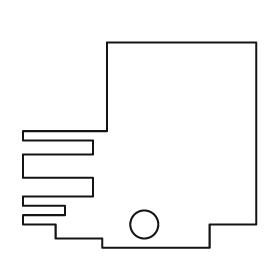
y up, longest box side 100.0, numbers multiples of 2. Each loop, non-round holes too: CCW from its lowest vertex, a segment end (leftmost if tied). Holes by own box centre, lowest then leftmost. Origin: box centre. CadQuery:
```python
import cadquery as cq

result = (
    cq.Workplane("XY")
    .moveTo(-16.0, -44.0)
    .lineTo(30.0, -44.0)
    .lineTo(30.0, -34.0)
    .lineTo(50.0, -34.0)
    .lineTo(50.0, 44.0)
    .lineTo(-14.0, 44.0)
    .lineTo(-14.0, 6.0)
    .lineTo(-50.0, 6.0)
    .lineTo(-50.0, 2.0)
    .lineTo(-20.0, 2.0)
    .lineTo(-20.0, -4.0)
    .lineTo(-50.0, -4.0)
    .lineTo(-50.0, -14.0)
    .lineTo(-20.0, -14.0)
    .lineTo(-20.0, -22.0)
    .lineTo(-50.0, -22.0)
    .lineTo(-50.0, -26.0)
    .lineTo(-32.0, -26.0)
    .lineTo(-32.0, -30.0)
    .lineTo(-50.0, -30.0)
    .lineTo(-50.0, -34.0)
    .lineTo(-36.0, -34.0)
    .lineTo(-36.0, -40.0)
    .lineTo(-16.0, -40.0)
    .close()
    .moveTo(2.0, -34.0)
    .circle(6.0)
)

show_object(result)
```